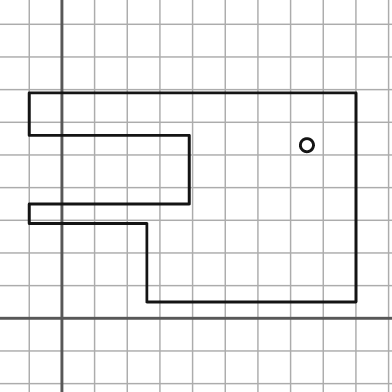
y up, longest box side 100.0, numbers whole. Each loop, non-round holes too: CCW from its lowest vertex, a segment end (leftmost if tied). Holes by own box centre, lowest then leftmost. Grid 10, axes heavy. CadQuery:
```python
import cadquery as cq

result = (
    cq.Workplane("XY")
    .moveTo(26.0, 5.0)
    .lineTo(90.0, 5.0)
    .lineTo(90.0, 69.0)
    .lineTo(-10.0, 69.0)
    .lineTo(-10.0, 56.0)
    .lineTo(39.0, 56.0)
    .lineTo(39.0, 35.0)
    .lineTo(-10.0, 35.0)
    .lineTo(-10.0, 29.0)
    .lineTo(26.0, 29.0)
    .close()
    .moveTo(75.0, 53.0)
    .circle(2.0)
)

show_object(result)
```